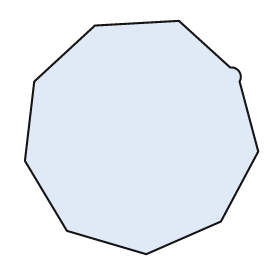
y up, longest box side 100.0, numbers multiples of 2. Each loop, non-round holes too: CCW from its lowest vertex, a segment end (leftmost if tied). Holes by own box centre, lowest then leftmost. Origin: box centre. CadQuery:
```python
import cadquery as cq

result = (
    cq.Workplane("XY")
    .moveTo(2.0, -50.0)
    .lineTo(34.0, -36.0)
    .lineTo(50.0, -6.0)
    .lineTo(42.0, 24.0)
    .threePointArc((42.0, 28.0), (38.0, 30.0))
    .lineTo(16.0, 50.0)
    .lineTo(-20.0, 48.0)
    .lineTo(-46.0, 24.0)
    .lineTo(-50.0, -10.0)
    .lineTo(-32.0, -40.0)
    .close()
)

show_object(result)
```